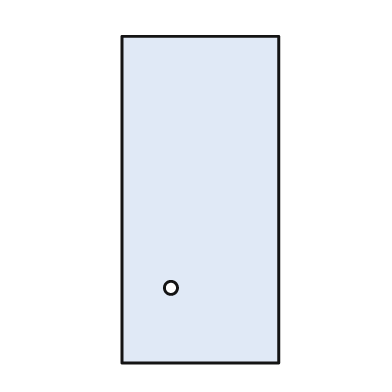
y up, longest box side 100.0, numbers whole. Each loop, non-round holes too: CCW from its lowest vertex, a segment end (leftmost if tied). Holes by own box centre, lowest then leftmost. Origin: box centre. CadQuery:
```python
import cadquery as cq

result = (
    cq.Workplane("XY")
    .moveTo(-24.0, -50.0)
    .lineTo(24.0, -50.0)
    .lineTo(24.0, 50.0)
    .lineTo(-24.0, 50.0)
    .close()
    .moveTo(-9.0, -27.0)
    .circle(2.0)
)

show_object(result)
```